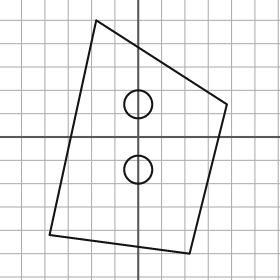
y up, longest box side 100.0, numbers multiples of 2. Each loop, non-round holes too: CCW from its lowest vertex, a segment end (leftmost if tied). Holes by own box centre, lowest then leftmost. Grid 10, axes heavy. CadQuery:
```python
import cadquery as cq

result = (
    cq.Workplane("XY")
    .moveTo(22.0, -50.0)
    .lineTo(38.0, 14.0)
    .lineTo(-18.0, 50.0)
    .lineTo(-38.0, -42.0)
    .close()
    .moveTo(0.0, -14.0)
    .circle(6.0)
    .moveTo(0.0, 14.0)
    .circle(6.0)
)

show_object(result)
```